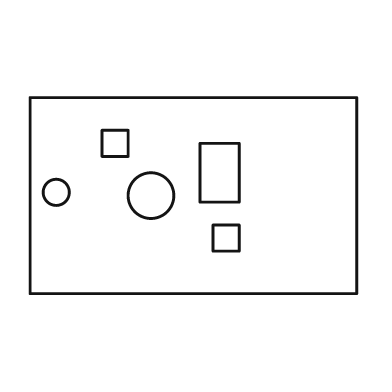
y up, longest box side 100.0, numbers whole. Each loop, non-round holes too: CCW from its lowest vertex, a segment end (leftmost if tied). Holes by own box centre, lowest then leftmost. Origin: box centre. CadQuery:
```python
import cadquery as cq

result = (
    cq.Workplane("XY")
    .moveTo(-50.0, -30.0)
    .lineTo(50.0, -30.0)
    .lineTo(50.0, 30.0)
    .lineTo(-50.0, 30.0)
    .close()
    .moveTo(6.0, -17.0)
    .lineTo(14.0, -17.0)
    .lineTo(14.0, -9.0)
    .lineTo(6.0, -9.0)
    .close()
    .moveTo(-13.0, 0.0)
    .circle(7.0)
    .moveTo(-42.0, 1.0)
    .circle(4.0)
    .moveTo(2.0, -2.0)
    .lineTo(14.0, -2.0)
    .lineTo(14.0, 16.0)
    .lineTo(2.0, 16.0)
    .close()
    .moveTo(-28.0, 12.0)
    .lineTo(-20.0, 12.0)
    .lineTo(-20.0, 20.0)
    .lineTo(-28.0, 20.0)
    .close()
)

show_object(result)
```